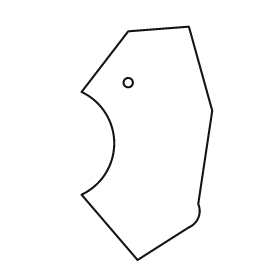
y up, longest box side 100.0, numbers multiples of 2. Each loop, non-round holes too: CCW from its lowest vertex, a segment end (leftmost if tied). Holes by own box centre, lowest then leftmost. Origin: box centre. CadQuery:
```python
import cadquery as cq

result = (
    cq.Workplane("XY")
    .moveTo(-4.0, -50.0)
    .lineTo(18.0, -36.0)
    .threePointArc((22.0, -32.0), (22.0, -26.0))
    .lineTo(28.0, 14.0)
    .lineTo(18.0, 50.0)
    .lineTo(-8.0, 48.0)
    .lineTo(-28.0, 22.0)
    .threePointArc((-14.0, 0.0), (-28.0, -22.0))
    .close()
    .moveTo(-8.0, 26.0)
    .circle(2.0)
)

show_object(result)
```